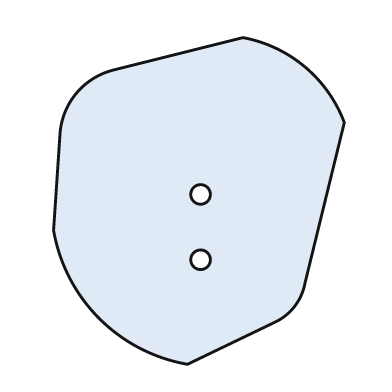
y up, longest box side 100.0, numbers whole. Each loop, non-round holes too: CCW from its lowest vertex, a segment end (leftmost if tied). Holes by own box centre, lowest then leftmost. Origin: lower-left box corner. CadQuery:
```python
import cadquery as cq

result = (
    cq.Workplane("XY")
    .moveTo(41.0, 0.0)
    .lineTo(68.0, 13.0)
    .threePointArc((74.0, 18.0), (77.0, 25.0))
    .lineTo(89.0, 74.0)
    .threePointArc((77.0, 91.0), (58.0, 100.0))
    .lineTo(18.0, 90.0)
    .threePointArc((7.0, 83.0), (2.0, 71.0))
    .lineTo(0.0, 41.0)
    .threePointArc((14.0, 14.0), (41.0, 0.0))
    .close()
    .moveTo(45.0, 32.0)
    .circle(3.0)
    .moveTo(45.0, 52.0)
    .circle(3.0)
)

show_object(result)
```